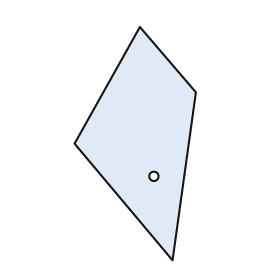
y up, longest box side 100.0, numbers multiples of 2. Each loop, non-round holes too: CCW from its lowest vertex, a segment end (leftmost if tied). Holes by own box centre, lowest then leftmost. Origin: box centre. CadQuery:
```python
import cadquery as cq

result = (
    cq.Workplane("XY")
    .moveTo(16.0, -50.0)
    .lineTo(26.0, 22.0)
    .lineTo(2.0, 50.0)
    .lineTo(-26.0, 0.0)
    .close()
    .moveTo(8.0, -14.0)
    .circle(2.0)
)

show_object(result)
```